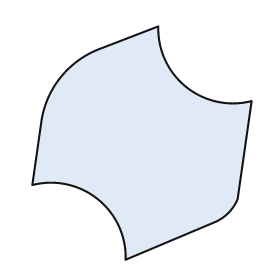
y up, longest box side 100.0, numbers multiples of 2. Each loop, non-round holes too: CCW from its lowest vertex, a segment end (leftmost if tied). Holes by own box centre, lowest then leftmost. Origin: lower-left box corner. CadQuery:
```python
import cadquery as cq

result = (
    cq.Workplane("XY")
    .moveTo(40.0, 0.0)
    .lineTo(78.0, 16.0)
    .threePointArc((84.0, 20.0), (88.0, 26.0))
    .lineTo(94.0, 68.0)
    .threePointArc((66.0, 74.0), (54.0, 100.0))
    .lineTo(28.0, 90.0)
    .threePointArc((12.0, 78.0), (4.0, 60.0))
    .lineTo(0.0, 32.0)
    .threePointArc((28.0, 26.0), (40.0, 0.0))
    .close()
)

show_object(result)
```